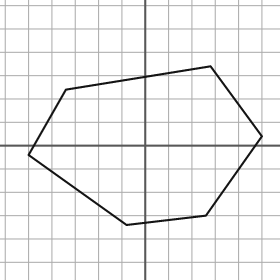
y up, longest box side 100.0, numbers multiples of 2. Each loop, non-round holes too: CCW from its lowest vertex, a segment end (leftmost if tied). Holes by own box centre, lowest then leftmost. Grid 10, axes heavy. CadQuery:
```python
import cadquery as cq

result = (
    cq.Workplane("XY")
    .moveTo(-8.0, -34.0)
    .lineTo(26.0, -30.0)
    .lineTo(50.0, 4.0)
    .lineTo(28.0, 34.0)
    .lineTo(-34.0, 24.0)
    .lineTo(-50.0, -4.0)
    .close()
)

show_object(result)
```